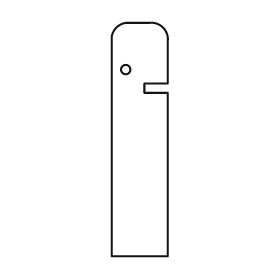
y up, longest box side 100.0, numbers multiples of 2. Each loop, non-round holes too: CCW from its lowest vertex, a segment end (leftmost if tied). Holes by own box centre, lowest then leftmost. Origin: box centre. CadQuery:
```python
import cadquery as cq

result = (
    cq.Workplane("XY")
    .moveTo(-12.0, -50.0)
    .lineTo(12.0, -50.0)
    .lineTo(12.0, 20.0)
    .lineTo(2.0, 20.0)
    .lineTo(2.0, 24.0)
    .lineTo(12.0, 24.0)
    .lineTo(12.0, 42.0)
    .threePointArc((10.0, 48.0), (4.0, 50.0))
    .lineTo(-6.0, 50.0)
    .threePointArc((-10.0, 48.0), (-12.0, 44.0))
    .close()
    .moveTo(-6.0, 30.0)
    .circle(2.0)
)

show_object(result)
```